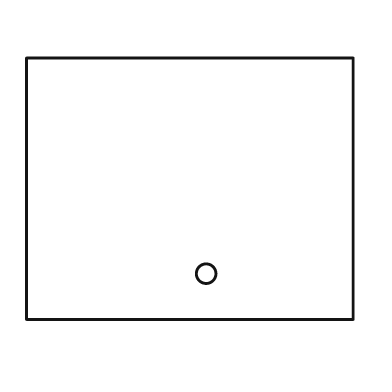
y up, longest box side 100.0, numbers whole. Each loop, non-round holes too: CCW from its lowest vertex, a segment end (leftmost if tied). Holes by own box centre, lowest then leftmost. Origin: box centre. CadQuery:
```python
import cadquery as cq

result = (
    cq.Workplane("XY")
    .moveTo(-50.0, -40.0)
    .lineTo(50.0, -40.0)
    .lineTo(50.0, 40.0)
    .lineTo(-50.0, 40.0)
    .close()
    .moveTo(5.0, -26.0)
    .circle(3.0)
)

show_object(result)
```